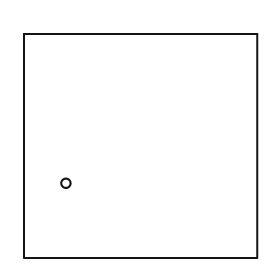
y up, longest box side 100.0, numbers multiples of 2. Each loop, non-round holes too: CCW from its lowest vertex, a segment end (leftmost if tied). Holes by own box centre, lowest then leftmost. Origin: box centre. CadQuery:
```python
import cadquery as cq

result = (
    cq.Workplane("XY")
    .moveTo(-50.0, -48.0)
    .lineTo(50.0, -48.0)
    .lineTo(50.0, 48.0)
    .lineTo(-50.0, 48.0)
    .close()
    .moveTo(-32.0, -16.0)
    .circle(2.0)
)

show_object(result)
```